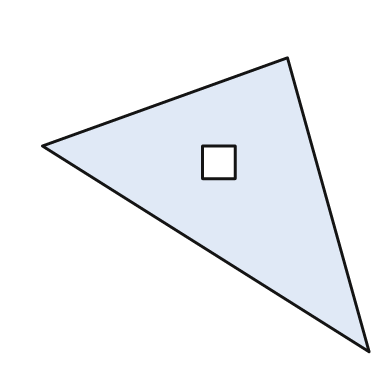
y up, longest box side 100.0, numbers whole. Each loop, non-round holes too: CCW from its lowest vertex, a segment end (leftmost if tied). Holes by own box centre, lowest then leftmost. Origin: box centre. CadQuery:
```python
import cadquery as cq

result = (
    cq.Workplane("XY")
    .moveTo(50.0, -45.0)
    .lineTo(25.0, 45.0)
    .lineTo(-50.0, 18.0)
    .close()
    .moveTo(-1.0, 8.0)
    .lineTo(9.0, 8.0)
    .lineTo(9.0, 18.0)
    .lineTo(-1.0, 18.0)
    .close()
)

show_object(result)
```